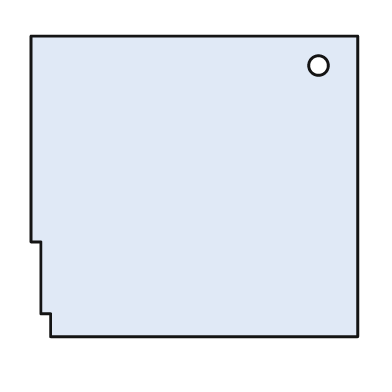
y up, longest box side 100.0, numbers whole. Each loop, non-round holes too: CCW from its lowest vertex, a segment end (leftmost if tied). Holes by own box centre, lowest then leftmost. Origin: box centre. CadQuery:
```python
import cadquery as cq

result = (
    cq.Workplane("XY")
    .moveTo(-44.0, -46.0)
    .lineTo(50.0, -46.0)
    .lineTo(50.0, 46.0)
    .lineTo(-50.0, 46.0)
    .lineTo(-50.0, -17.0)
    .lineTo(-47.0, -17.0)
    .lineTo(-47.0, -39.0)
    .lineTo(-44.0, -39.0)
    .close()
    .moveTo(38.0, 37.0)
    .circle(3.0)
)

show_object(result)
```